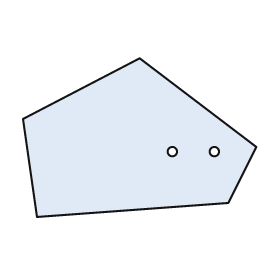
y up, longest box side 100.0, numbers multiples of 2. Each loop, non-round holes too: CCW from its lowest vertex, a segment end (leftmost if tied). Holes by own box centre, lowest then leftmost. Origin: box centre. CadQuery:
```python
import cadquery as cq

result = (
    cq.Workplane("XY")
    .moveTo(-44.0, -34.0)
    .lineTo(38.0, -28.0)
    .lineTo(50.0, -4.0)
    .lineTo(0.0, 34.0)
    .lineTo(-50.0, 8.0)
    .close()
    .moveTo(14.0, -6.0)
    .circle(2.0)
    .moveTo(32.0, -6.0)
    .circle(2.0)
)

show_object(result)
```